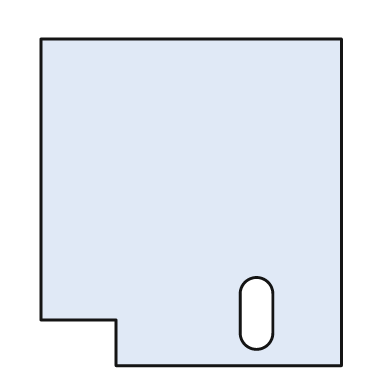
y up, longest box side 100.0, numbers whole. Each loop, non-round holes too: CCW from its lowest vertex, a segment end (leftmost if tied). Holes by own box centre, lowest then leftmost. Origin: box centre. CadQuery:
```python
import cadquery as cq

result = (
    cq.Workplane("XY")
    .moveTo(-23.0, -50.0)
    .lineTo(46.0, -50.0)
    .lineTo(46.0, 50.0)
    .lineTo(-46.0, 50.0)
    .lineTo(-46.0, -36.0)
    .lineTo(-23.0, -36.0)
    .close()
    .moveTo(15.0, -40.0)
    .threePointArc((20.0, -45.0), (25.0, -40.0))
    .lineTo(25.0, -28.0)
    .threePointArc((20.0, -23.0), (15.0, -28.0))
    .close()
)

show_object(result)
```